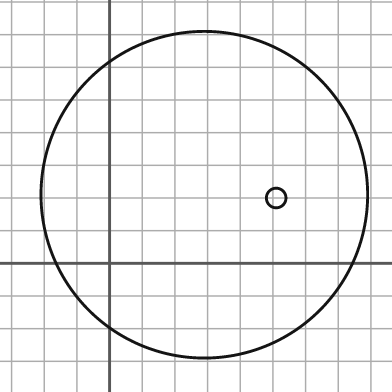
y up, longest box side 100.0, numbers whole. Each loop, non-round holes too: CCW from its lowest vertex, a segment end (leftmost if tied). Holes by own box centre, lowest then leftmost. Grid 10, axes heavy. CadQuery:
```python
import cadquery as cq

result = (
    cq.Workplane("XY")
    .moveTo(29.0, 21.0)
    .circle(50.0)
    .moveTo(51.0, 20.0)
    .circle(3.0)
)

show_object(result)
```